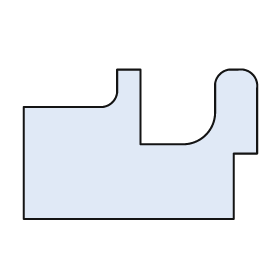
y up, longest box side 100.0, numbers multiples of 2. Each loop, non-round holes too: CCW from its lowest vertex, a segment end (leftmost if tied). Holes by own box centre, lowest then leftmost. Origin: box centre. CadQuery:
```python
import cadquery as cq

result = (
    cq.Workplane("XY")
    .moveTo(-50.0, -32.0)
    .lineTo(40.0, -32.0)
    .lineTo(40.0, -4.0)
    .lineTo(50.0, -4.0)
    .lineTo(50.0, 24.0)
    .threePointArc((48.0, 30.0), (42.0, 32.0))
    .lineTo(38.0, 32.0)
    .threePointArc((34.0, 30.0), (32.0, 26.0))
    .lineTo(32.0, 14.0)
    .threePointArc((28.0, 4.0), (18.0, 0.0))
    .lineTo(0.0, 0.0)
    .lineTo(0.0, 32.0)
    .lineTo(-10.0, 32.0)
    .lineTo(-10.0, 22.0)
    .threePointArc((-12.0, 18.0), (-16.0, 16.0))
    .lineTo(-50.0, 16.0)
    .close()
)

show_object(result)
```